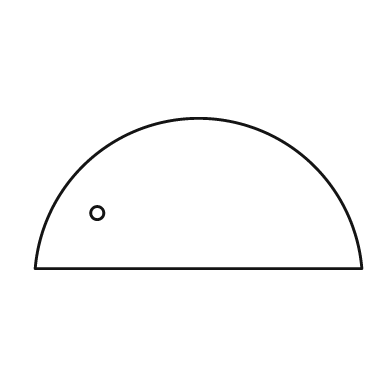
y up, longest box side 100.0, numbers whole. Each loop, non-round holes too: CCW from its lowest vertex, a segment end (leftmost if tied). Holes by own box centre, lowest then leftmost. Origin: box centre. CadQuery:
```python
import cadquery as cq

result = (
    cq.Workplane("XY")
    .moveTo(-50.0, -23.0)
    .lineTo(50.0, -23.0)
    .threePointArc((0.0, 23.0), (-50.0, -23.0))
    .close()
    .moveTo(-31.0, -6.0)
    .circle(2.0)
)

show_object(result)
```